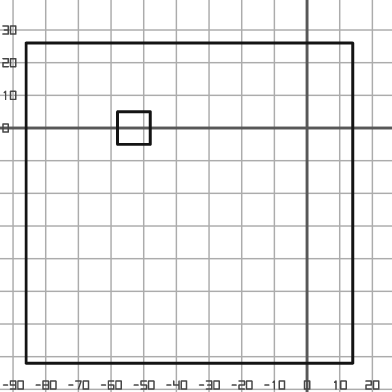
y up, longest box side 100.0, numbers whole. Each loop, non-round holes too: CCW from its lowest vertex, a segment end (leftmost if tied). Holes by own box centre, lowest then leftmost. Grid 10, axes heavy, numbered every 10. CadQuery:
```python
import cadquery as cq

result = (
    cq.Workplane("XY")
    .moveTo(-86.0, -72.0)
    .lineTo(14.0, -72.0)
    .lineTo(14.0, 26.0)
    .lineTo(-86.0, 26.0)
    .close()
    .moveTo(-58.0, -5.0)
    .lineTo(-48.0, -5.0)
    .lineTo(-48.0, 5.0)
    .lineTo(-58.0, 5.0)
    .close()
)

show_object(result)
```